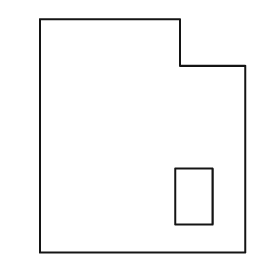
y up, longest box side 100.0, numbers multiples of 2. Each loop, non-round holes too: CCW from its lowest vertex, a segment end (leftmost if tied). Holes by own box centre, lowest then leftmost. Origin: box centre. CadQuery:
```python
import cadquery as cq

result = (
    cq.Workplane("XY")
    .moveTo(-44.0, -50.0)
    .lineTo(44.0, -50.0)
    .lineTo(44.0, 30.0)
    .lineTo(16.0, 30.0)
    .lineTo(16.0, 50.0)
    .lineTo(-44.0, 50.0)
    .close()
    .moveTo(14.0, -38.0)
    .lineTo(30.0, -38.0)
    .lineTo(30.0, -14.0)
    .lineTo(14.0, -14.0)
    .close()
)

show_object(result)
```